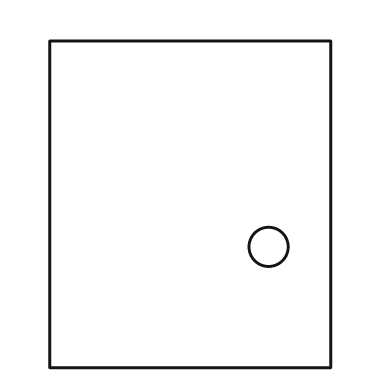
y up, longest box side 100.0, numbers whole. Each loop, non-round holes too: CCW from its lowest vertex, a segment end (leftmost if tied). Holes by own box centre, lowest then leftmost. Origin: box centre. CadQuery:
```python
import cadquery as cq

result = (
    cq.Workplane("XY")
    .moveTo(-43.0, -50.0)
    .lineTo(43.0, -50.0)
    .lineTo(43.0, 50.0)
    .lineTo(-43.0, 50.0)
    .close()
    .moveTo(24.0, -13.0)
    .circle(6.0)
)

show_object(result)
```